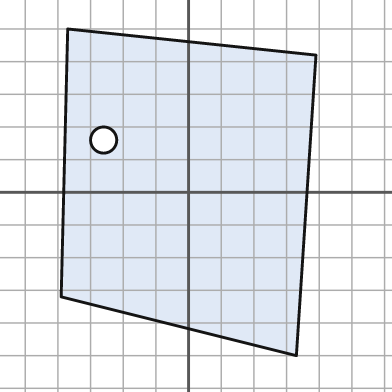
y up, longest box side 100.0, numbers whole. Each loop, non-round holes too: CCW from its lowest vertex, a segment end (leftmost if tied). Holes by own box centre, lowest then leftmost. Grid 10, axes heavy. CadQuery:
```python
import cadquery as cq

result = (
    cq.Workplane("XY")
    .moveTo(33.0, -50.0)
    .lineTo(39.0, 42.0)
    .lineTo(-37.0, 50.0)
    .lineTo(-39.0, -32.0)
    .close()
    .moveTo(-26.0, 16.0)
    .circle(4.0)
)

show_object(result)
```